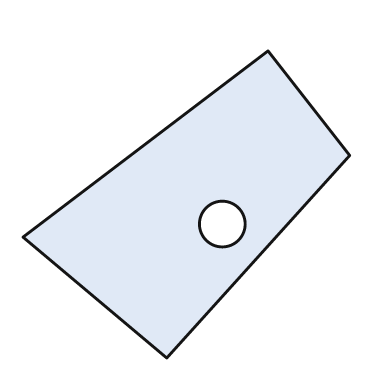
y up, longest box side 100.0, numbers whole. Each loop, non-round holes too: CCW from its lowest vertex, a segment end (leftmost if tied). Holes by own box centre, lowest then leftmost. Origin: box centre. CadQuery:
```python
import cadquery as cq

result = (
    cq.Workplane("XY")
    .moveTo(-6.0, -47.0)
    .lineTo(50.0, 15.0)
    .lineTo(25.0, 47.0)
    .lineTo(-50.0, -10.0)
    .close()
    .moveTo(11.0, -6.0)
    .circle(7.0)
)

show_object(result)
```